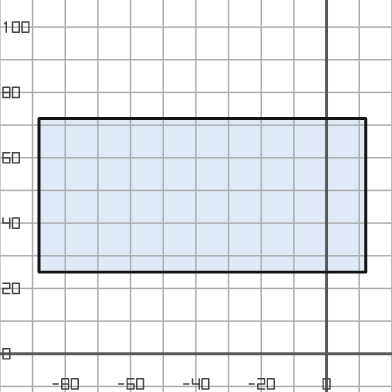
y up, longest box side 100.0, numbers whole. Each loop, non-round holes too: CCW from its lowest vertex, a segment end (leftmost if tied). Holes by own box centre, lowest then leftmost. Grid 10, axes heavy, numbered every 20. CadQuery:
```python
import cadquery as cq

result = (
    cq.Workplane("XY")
    .moveTo(-88.0, 25.0)
    .lineTo(12.0, 25.0)
    .lineTo(12.0, 72.0)
    .lineTo(-88.0, 72.0)
    .close()
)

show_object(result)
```